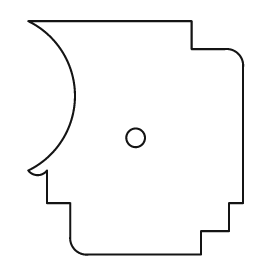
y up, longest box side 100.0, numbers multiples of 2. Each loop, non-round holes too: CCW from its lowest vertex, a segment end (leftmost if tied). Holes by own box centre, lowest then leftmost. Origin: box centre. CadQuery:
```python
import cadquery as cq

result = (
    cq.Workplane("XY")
    .moveTo(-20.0, -50.0)
    .lineTo(28.0, -50.0)
    .lineTo(28.0, -40.0)
    .lineTo(40.0, -40.0)
    .lineTo(40.0, -28.0)
    .lineTo(46.0, -28.0)
    .lineTo(46.0, 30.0)
    .threePointArc((44.0, 36.0), (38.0, 38.0))
    .lineTo(24.0, 38.0)
    .lineTo(24.0, 50.0)
    .lineTo(-46.0, 50.0)
    .threePointArc((-26.0, 18.0), (-46.0, -14.0))
    .threePointArc((-42.0, -16.0), (-38.0, -14.0))
    .lineTo(-38.0, -28.0)
    .lineTo(-28.0, -28.0)
    .lineTo(-28.0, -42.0)
    .threePointArc((-26.0, -48.0), (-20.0, -50.0))
    .close()
    .moveTo(0.0, 0.0)
    .circle(4.0)
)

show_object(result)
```